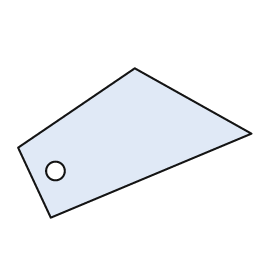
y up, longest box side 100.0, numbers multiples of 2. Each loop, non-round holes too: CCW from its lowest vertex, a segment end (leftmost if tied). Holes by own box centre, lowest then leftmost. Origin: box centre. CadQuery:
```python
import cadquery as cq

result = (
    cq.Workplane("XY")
    .moveTo(-36.0, -32.0)
    .lineTo(50.0, 4.0)
    .lineTo(0.0, 32.0)
    .lineTo(-50.0, -2.0)
    .close()
    .moveTo(-34.0, -12.0)
    .circle(4.0)
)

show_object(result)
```